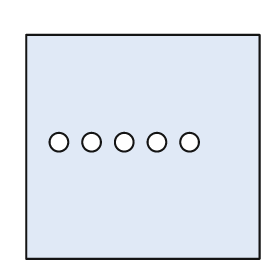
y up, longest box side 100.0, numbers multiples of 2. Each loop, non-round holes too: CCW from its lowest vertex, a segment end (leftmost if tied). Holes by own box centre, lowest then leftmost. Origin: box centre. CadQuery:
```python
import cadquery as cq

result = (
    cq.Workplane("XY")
    .moveTo(-50.0, -48.0)
    .lineTo(50.0, -48.0)
    .lineTo(50.0, 48.0)
    .lineTo(-50.0, 48.0)
    .close()
    .moveTo(-36.0, 2.0)
    .circle(4.0)
    .moveTo(-22.0, 2.0)
    .circle(4.0)
    .moveTo(-8.0, 2.0)
    .circle(4.0)
    .moveTo(6.0, 2.0)
    .circle(4.0)
    .moveTo(20.0, 2.0)
    .circle(4.0)
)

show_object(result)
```